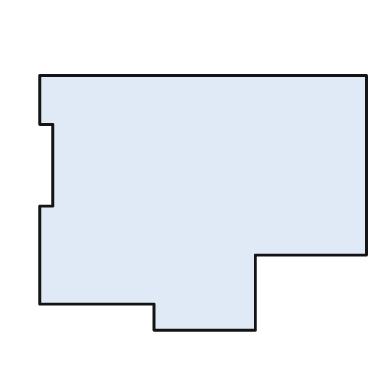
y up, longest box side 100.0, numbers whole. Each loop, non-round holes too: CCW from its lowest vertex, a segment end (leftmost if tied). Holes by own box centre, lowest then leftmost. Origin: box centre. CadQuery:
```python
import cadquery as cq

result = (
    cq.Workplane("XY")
    .moveTo(-15.0, -39.0)
    .lineTo(16.0, -39.0)
    .lineTo(16.0, -16.0)
    .lineTo(50.0, -16.0)
    .lineTo(50.0, 39.0)
    .lineTo(-50.0, 39.0)
    .lineTo(-50.0, 24.0)
    .lineTo(-46.0, 24.0)
    .lineTo(-46.0, -1.0)
    .lineTo(-50.0, -1.0)
    .lineTo(-50.0, -31.0)
    .lineTo(-15.0, -31.0)
    .close()
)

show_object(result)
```